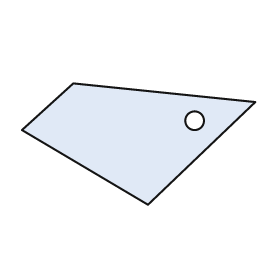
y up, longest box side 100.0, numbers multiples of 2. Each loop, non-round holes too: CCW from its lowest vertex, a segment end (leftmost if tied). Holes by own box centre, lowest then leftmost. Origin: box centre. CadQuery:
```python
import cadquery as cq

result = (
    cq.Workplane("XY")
    .moveTo(4.0, -26.0)
    .lineTo(50.0, 18.0)
    .lineTo(-28.0, 26.0)
    .lineTo(-50.0, 6.0)
    .close()
    .moveTo(24.0, 10.0)
    .circle(4.0)
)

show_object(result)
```